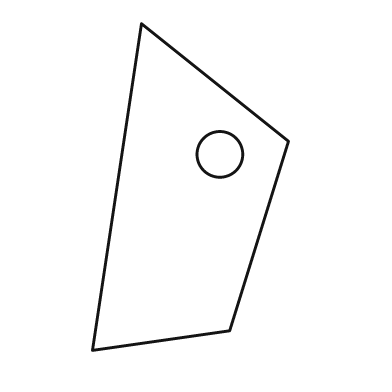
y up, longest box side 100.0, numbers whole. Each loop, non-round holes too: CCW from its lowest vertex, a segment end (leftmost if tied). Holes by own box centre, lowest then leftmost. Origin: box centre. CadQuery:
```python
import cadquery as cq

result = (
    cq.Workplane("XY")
    .moveTo(-30.0, -50.0)
    .lineTo(12.0, -44.0)
    .lineTo(30.0, 14.0)
    .lineTo(-15.0, 50.0)
    .close()
    .moveTo(9.0, 10.0)
    .circle(7.0)
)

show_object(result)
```